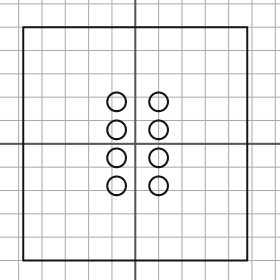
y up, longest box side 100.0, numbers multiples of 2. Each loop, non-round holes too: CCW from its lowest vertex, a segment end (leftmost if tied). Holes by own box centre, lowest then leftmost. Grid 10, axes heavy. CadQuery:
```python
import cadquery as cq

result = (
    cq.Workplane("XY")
    .moveTo(-48.0, -50.0)
    .lineTo(48.0, -50.0)
    .lineTo(48.0, 50.0)
    .lineTo(-48.0, 50.0)
    .close()
    .moveTo(-8.0, -18.0)
    .circle(4.0)
    .moveTo(10.0, -18.0)
    .circle(4.0)
    .moveTo(-8.0, -6.0)
    .circle(4.0)
    .moveTo(10.0, -6.0)
    .circle(4.0)
    .moveTo(-8.0, 6.0)
    .circle(4.0)
    .moveTo(10.0, 6.0)
    .circle(4.0)
    .moveTo(-8.0, 18.0)
    .circle(4.0)
    .moveTo(10.0, 18.0)
    .circle(4.0)
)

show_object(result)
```